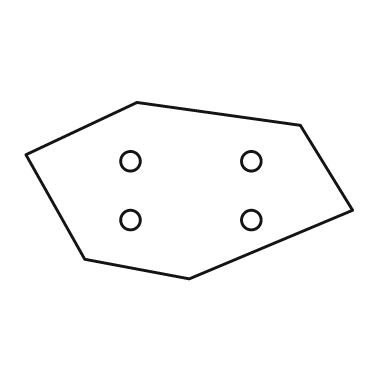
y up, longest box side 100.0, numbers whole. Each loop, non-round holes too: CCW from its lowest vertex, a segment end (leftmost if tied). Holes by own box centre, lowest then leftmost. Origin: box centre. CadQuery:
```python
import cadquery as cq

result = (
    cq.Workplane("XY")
    .moveTo(0.0, -27.0)
    .lineTo(50.0, -6.0)
    .lineTo(34.0, 20.0)
    .lineTo(-16.0, 27.0)
    .lineTo(-50.0, 11.0)
    .lineTo(-32.0, -21.0)
    .close()
    .moveTo(-18.0, -9.0)
    .circle(3.0)
    .moveTo(19.0, -9.0)
    .circle(3.0)
    .moveTo(-18.0, 9.0)
    .circle(3.0)
    .moveTo(19.0, 9.0)
    .circle(3.0)
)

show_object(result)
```